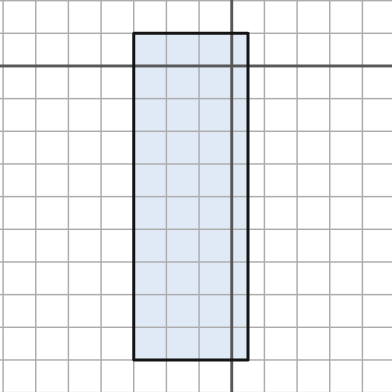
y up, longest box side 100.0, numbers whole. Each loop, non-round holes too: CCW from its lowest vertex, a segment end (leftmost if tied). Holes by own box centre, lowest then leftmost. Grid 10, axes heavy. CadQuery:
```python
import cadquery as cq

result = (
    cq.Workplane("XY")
    .moveTo(-30.0, -90.0)
    .lineTo(5.0, -90.0)
    .lineTo(5.0, 10.0)
    .lineTo(-30.0, 10.0)
    .close()
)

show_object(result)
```